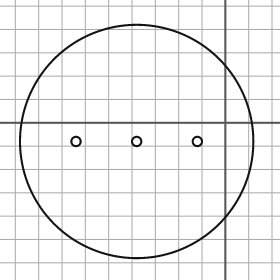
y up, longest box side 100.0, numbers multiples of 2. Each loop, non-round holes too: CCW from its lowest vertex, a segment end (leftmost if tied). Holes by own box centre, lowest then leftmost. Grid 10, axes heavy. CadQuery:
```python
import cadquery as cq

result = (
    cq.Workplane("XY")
    .moveTo(-38.0, -8.0)
    .circle(50.0)
    .moveTo(-64.0, -8.0)
    .circle(2.0)
    .moveTo(-38.0, -8.0)
    .circle(2.0)
    .moveTo(-12.0, -8.0)
    .circle(2.0)
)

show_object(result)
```